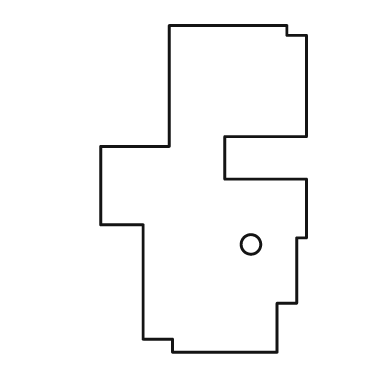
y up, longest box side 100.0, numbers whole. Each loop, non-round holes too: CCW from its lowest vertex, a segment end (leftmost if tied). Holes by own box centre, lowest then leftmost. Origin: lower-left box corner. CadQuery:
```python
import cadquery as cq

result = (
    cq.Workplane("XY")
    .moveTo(22.0, 0.0)
    .lineTo(54.0, 0.0)
    .lineTo(54.0, 15.0)
    .lineTo(60.0, 15.0)
    .lineTo(60.0, 35.0)
    .lineTo(63.0, 35.0)
    .lineTo(63.0, 53.0)
    .lineTo(38.0, 53.0)
    .lineTo(38.0, 66.0)
    .lineTo(63.0, 66.0)
    .lineTo(63.0, 97.0)
    .lineTo(57.0, 97.0)
    .lineTo(57.0, 100.0)
    .lineTo(21.0, 100.0)
    .lineTo(21.0, 63.0)
    .lineTo(0.0, 63.0)
    .lineTo(0.0, 39.0)
    .lineTo(13.0, 39.0)
    .lineTo(13.0, 4.0)
    .lineTo(22.0, 4.0)
    .close()
    .moveTo(46.0, 33.0)
    .circle(3.0)
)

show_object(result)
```